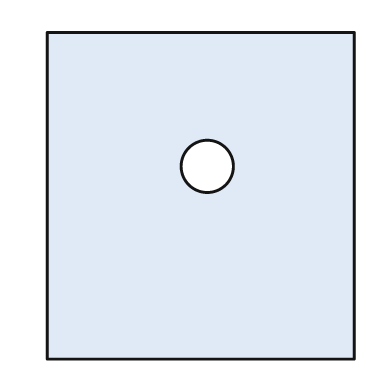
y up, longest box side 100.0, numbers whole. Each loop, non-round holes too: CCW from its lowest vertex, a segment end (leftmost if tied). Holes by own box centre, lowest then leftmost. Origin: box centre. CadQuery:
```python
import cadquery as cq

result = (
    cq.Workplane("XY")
    .moveTo(-47.0, -50.0)
    .lineTo(47.0, -50.0)
    .lineTo(47.0, 50.0)
    .lineTo(-47.0, 50.0)
    .close()
    .moveTo(2.0, 9.0)
    .circle(8.0)
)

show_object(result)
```